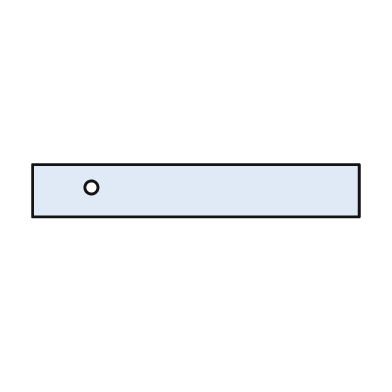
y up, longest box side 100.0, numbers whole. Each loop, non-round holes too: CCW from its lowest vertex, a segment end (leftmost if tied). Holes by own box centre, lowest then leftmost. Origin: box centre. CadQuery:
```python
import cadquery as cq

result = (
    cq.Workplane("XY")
    .moveTo(-50.0, -8.0)
    .lineTo(50.0, -8.0)
    .lineTo(50.0, 8.0)
    .lineTo(-50.0, 8.0)
    .close()
    .moveTo(-32.0, 1.0)
    .circle(2.0)
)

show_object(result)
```